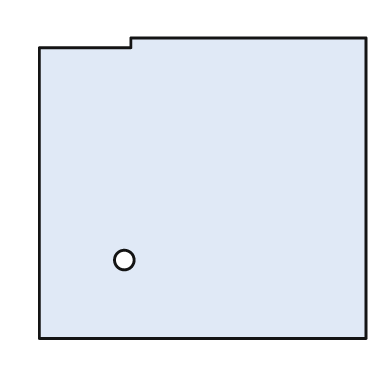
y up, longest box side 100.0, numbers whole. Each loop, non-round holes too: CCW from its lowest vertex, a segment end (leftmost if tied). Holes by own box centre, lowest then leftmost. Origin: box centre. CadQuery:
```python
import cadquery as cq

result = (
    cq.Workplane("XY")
    .moveTo(-50.0, -46.0)
    .lineTo(50.0, -46.0)
    .lineTo(50.0, 46.0)
    .lineTo(-22.0, 46.0)
    .lineTo(-22.0, 43.0)
    .lineTo(-50.0, 43.0)
    .close()
    .moveTo(-24.0, -22.0)
    .circle(3.0)
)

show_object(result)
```